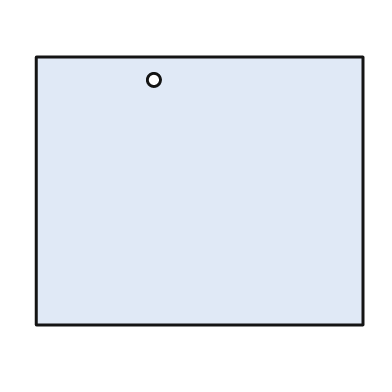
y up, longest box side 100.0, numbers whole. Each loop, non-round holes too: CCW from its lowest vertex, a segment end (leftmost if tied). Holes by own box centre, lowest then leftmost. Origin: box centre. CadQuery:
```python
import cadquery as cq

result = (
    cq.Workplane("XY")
    .moveTo(-50.0, -41.0)
    .lineTo(50.0, -41.0)
    .lineTo(50.0, 41.0)
    .lineTo(-50.0, 41.0)
    .close()
    .moveTo(-14.0, 34.0)
    .circle(2.0)
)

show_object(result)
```